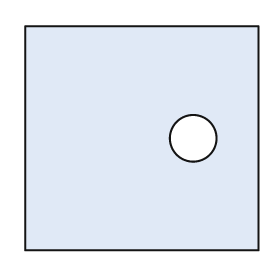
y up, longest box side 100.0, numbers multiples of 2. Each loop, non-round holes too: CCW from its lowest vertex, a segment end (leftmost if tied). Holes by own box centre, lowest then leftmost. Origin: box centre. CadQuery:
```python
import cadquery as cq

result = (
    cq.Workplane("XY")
    .moveTo(-50.0, -48.0)
    .lineTo(50.0, -48.0)
    .lineTo(50.0, 48.0)
    .lineTo(-50.0, 48.0)
    .close()
    .moveTo(22.0, 0.0)
    .circle(10.0)
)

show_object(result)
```